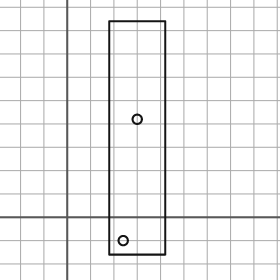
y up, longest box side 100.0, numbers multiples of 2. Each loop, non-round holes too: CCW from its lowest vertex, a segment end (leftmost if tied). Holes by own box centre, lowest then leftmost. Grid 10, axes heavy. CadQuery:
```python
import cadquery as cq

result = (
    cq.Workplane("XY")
    .moveTo(18.0, -16.0)
    .lineTo(42.0, -16.0)
    .lineTo(42.0, 84.0)
    .lineTo(18.0, 84.0)
    .close()
    .moveTo(24.0, -10.0)
    .circle(2.0)
    .moveTo(30.0, 42.0)
    .circle(2.0)
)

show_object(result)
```